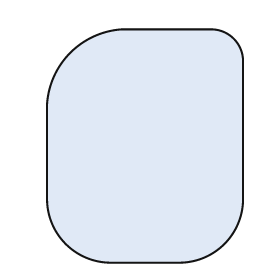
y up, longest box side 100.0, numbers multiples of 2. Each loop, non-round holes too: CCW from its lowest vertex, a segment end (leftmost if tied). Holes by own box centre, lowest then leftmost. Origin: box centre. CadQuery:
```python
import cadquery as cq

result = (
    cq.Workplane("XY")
    .moveTo(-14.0, -50.0)
    .lineTo(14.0, -50.0)
    .threePointArc((34.0, -42.0), (42.0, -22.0))
    .lineTo(42.0, 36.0)
    .threePointArc((38.0, 46.0), (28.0, 50.0))
    .lineTo(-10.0, 50.0)
    .threePointArc((-32.0, 40.0), (-42.0, 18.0))
    .lineTo(-42.0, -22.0)
    .threePointArc((-34.0, -42.0), (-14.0, -50.0))
    .close()
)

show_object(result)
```